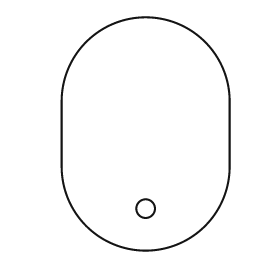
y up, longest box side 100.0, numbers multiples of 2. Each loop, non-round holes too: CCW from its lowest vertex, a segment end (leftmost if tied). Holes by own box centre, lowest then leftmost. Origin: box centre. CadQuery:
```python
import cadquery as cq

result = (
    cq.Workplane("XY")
    .moveTo(-36.0, -14.0)
    .threePointArc((0.0, -50.0), (36.0, -14.0))
    .lineTo(36.0, 14.0)
    .threePointArc((0.0, 50.0), (-36.0, 14.0))
    .close()
    .moveTo(0.0, -32.0)
    .circle(4.0)
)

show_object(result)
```